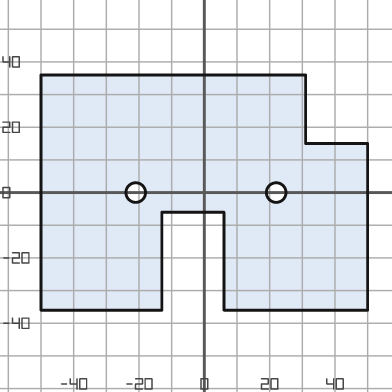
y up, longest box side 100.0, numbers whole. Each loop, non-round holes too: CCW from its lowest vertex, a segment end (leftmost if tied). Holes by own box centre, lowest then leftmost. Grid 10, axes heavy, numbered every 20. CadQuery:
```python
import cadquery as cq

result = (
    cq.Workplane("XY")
    .moveTo(-50.0, -36.0)
    .lineTo(-13.0, -36.0)
    .lineTo(-13.0, -6.0)
    .lineTo(6.0, -6.0)
    .lineTo(6.0, -36.0)
    .lineTo(50.0, -36.0)
    .lineTo(50.0, 15.0)
    .lineTo(31.0, 15.0)
    .lineTo(31.0, 36.0)
    .lineTo(-50.0, 36.0)
    .close()
    .moveTo(-21.0, 0.0)
    .circle(3.0)
    .moveTo(22.0, 0.0)
    .circle(3.0)
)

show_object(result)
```